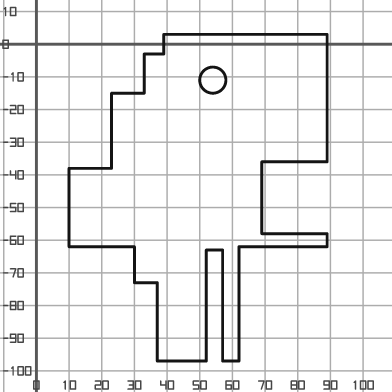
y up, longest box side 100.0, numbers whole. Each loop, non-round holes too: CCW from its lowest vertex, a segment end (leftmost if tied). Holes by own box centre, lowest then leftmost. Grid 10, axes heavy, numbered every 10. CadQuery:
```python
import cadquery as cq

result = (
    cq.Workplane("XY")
    .moveTo(37.0, -97.0)
    .lineTo(52.0, -97.0)
    .lineTo(52.0, -63.0)
    .lineTo(57.0, -63.0)
    .lineTo(57.0, -97.0)
    .lineTo(62.0, -97.0)
    .lineTo(62.0, -62.0)
    .lineTo(89.0, -62.0)
    .lineTo(89.0, -58.0)
    .lineTo(69.0, -58.0)
    .lineTo(69.0, -36.0)
    .lineTo(89.0, -36.0)
    .lineTo(89.0, 3.0)
    .lineTo(39.0, 3.0)
    .lineTo(39.0, -3.0)
    .lineTo(33.0, -3.0)
    .lineTo(33.0, -15.0)
    .lineTo(23.0, -15.0)
    .lineTo(23.0, -38.0)
    .lineTo(10.0, -38.0)
    .lineTo(10.0, -62.0)
    .lineTo(30.0, -62.0)
    .lineTo(30.0, -73.0)
    .lineTo(37.0, -73.0)
    .close()
    .moveTo(54.0, -11.0)
    .circle(4.0)
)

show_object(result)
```